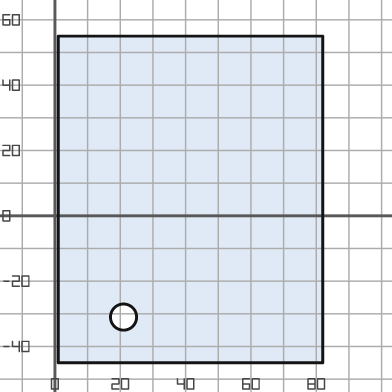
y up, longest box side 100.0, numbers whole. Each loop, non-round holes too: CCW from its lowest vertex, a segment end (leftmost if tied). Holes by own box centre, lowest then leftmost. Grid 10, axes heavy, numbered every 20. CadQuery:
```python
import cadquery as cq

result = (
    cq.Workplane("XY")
    .moveTo(1.0, -45.0)
    .lineTo(82.0, -45.0)
    .lineTo(82.0, 55.0)
    .lineTo(1.0, 55.0)
    .close()
    .moveTo(21.0, -31.0)
    .circle(4.0)
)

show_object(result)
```